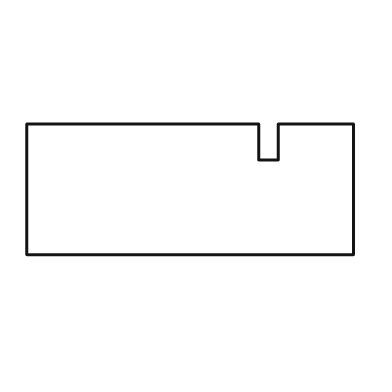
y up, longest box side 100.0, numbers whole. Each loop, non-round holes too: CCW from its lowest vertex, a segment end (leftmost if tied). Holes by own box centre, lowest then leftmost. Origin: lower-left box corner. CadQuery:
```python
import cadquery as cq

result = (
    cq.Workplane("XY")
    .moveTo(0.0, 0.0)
    .lineTo(100.0, 0.0)
    .lineTo(100.0, 40.0)
    .lineTo(77.0, 40.0)
    .lineTo(77.0, 29.0)
    .lineTo(71.0, 29.0)
    .lineTo(71.0, 40.0)
    .lineTo(0.0, 40.0)
    .close()
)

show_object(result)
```